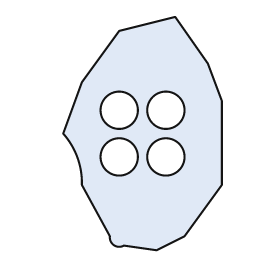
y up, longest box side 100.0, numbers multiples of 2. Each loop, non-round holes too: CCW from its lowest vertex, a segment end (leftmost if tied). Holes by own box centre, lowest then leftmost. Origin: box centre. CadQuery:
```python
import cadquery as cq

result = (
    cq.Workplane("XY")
    .moveTo(6.0, -50.0)
    .lineTo(18.0, -44.0)
    .lineTo(34.0, -22.0)
    .lineTo(34.0, 14.0)
    .lineTo(28.0, 30.0)
    .lineTo(14.0, 50.0)
    .lineTo(-10.0, 44.0)
    .lineTo(-26.0, 22.0)
    .lineTo(-34.0, 0.0)
    .threePointArc((-28.0, -10.0), (-26.0, -22.0))
    .lineTo(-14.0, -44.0)
    .threePointArc((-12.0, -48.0), (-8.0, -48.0))
    .close()
    .moveTo(-10.0, -10.0)
    .circle(8.0)
    .moveTo(10.0, -10.0)
    .circle(8.0)
    .moveTo(-10.0, 10.0)
    .circle(8.0)
    .moveTo(10.0, 10.0)
    .circle(8.0)
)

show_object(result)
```